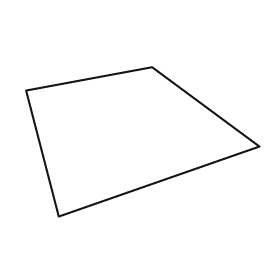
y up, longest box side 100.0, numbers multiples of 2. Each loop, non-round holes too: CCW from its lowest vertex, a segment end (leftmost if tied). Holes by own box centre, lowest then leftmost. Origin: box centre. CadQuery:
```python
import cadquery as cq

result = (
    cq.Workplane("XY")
    .moveTo(-36.0, -32.0)
    .lineTo(50.0, -2.0)
    .lineTo(4.0, 32.0)
    .lineTo(-50.0, 22.0)
    .close()
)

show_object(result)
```